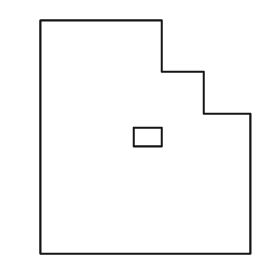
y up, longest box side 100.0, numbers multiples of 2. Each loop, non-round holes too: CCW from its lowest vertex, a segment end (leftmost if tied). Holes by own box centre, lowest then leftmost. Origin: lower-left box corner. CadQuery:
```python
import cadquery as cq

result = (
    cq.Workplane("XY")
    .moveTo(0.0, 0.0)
    .lineTo(90.0, 0.0)
    .lineTo(90.0, 60.0)
    .lineTo(70.0, 60.0)
    .lineTo(70.0, 78.0)
    .lineTo(52.0, 78.0)
    .lineTo(52.0, 100.0)
    .lineTo(0.0, 100.0)
    .close()
    .moveTo(40.0, 46.0)
    .lineTo(52.0, 46.0)
    .lineTo(52.0, 54.0)
    .lineTo(40.0, 54.0)
    .close()
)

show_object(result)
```